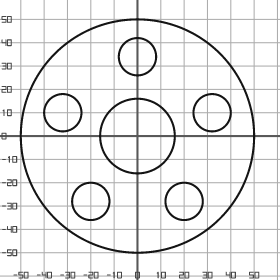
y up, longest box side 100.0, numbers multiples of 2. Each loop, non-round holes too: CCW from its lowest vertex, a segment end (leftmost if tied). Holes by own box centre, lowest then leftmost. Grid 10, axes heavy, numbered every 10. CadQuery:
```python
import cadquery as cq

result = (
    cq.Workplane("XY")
    .moveTo(0.0, 0.0)
    .circle(50.0)
    .moveTo(-20.0, -28.0)
    .circle(8.0)
    .moveTo(20.0, -28.0)
    .circle(8.0)
    .moveTo(0.0, 0.0)
    .circle(16.0)
    .moveTo(-32.0, 10.0)
    .circle(8.0)
    .moveTo(32.0, 10.0)
    .circle(8.0)
    .moveTo(0.0, 34.0)
    .circle(8.0)
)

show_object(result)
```